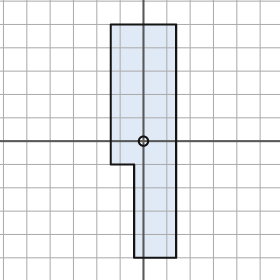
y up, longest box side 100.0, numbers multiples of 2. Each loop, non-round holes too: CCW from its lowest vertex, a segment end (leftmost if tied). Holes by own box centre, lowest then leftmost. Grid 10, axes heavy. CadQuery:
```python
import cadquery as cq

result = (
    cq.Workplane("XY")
    .moveTo(-4.0, -50.0)
    .lineTo(14.0, -50.0)
    .lineTo(14.0, 50.0)
    .lineTo(-14.0, 50.0)
    .lineTo(-14.0, -10.0)
    .lineTo(-4.0, -10.0)
    .close()
    .moveTo(0.0, 0.0)
    .circle(2.0)
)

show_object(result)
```